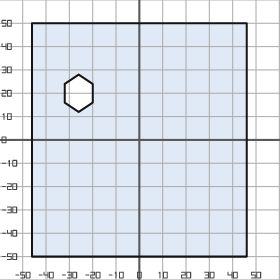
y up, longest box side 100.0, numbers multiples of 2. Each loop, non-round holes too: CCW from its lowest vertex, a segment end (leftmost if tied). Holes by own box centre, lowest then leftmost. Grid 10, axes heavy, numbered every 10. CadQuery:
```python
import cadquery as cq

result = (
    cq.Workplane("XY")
    .moveTo(-46.0, -50.0)
    .lineTo(46.0, -50.0)
    .lineTo(46.0, 50.0)
    .lineTo(-46.0, 50.0)
    .close()
    .moveTo(-26.0, 12.0)
    .lineTo(-20.0, 16.0)
    .lineTo(-20.0, 24.0)
    .lineTo(-26.0, 28.0)
    .lineTo(-32.0, 24.0)
    .lineTo(-32.0, 16.0)
    .close()
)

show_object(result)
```